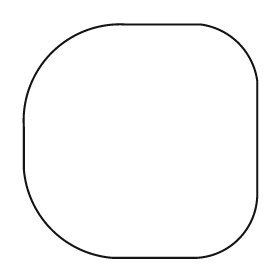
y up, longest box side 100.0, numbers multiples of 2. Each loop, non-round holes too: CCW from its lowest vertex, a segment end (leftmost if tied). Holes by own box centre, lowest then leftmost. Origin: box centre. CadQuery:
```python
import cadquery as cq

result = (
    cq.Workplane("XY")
    .moveTo(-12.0, -50.0)
    .lineTo(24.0, -50.0)
    .threePointArc((42.0, -42.0), (50.0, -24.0))
    .lineTo(50.0, 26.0)
    .threePointArc((42.0, 42.0), (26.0, 50.0))
    .lineTo(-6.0, 50.0)
    .threePointArc((-38.0, 38.0), (-50.0, 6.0))
    .lineTo(-50.0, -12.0)
    .threePointArc((-38.0, -38.0), (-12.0, -50.0))
    .close()
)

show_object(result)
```